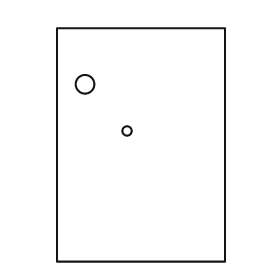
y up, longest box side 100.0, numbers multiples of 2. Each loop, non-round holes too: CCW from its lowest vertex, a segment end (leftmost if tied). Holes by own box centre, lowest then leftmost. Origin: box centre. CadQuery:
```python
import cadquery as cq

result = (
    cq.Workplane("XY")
    .moveTo(-36.0, -50.0)
    .lineTo(36.0, -50.0)
    .lineTo(36.0, 50.0)
    .lineTo(-36.0, 50.0)
    .close()
    .moveTo(-6.0, 6.0)
    .circle(2.0)
    .moveTo(-24.0, 26.0)
    .circle(4.0)
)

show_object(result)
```